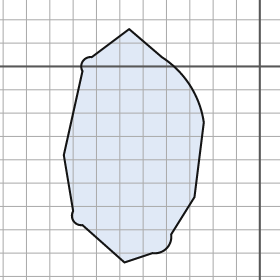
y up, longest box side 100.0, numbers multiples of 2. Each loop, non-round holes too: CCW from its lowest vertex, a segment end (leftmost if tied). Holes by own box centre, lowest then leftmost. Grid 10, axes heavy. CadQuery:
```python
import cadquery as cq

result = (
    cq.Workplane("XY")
    .moveTo(-58.0, -84.0)
    .lineTo(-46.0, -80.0)
    .threePointArc((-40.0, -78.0), (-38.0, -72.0))
    .lineTo(-28.0, -56.0)
    .lineTo(-24.0, -24.0)
    .threePointArc((-30.0, -8.0), (-42.0, 4.0))
    .lineTo(-56.0, 16.0)
    .lineTo(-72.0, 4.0)
    .threePointArc((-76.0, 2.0), (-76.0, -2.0))
    .lineTo(-84.0, -38.0)
    .lineTo(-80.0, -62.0)
    .threePointArc((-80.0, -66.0), (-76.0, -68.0))
    .close()
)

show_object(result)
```